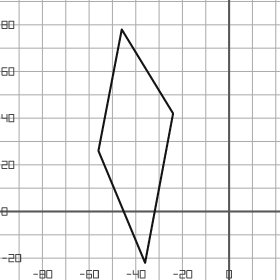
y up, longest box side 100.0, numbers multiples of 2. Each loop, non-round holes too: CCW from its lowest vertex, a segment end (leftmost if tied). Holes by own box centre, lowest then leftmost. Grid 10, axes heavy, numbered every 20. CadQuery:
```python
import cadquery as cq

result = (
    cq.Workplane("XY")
    .moveTo(-36.0, -22.0)
    .lineTo(-24.0, 42.0)
    .lineTo(-46.0, 78.0)
    .lineTo(-56.0, 26.0)
    .close()
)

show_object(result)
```